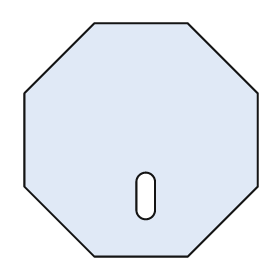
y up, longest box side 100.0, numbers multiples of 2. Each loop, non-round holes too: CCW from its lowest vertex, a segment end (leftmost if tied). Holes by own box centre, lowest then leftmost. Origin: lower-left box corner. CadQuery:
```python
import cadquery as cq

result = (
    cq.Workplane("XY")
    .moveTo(30.0, 0.0)
    .lineTo(70.0, 0.0)
    .lineTo(100.0, 30.0)
    .lineTo(100.0, 70.0)
    .lineTo(70.0, 100.0)
    .lineTo(30.0, 100.0)
    .lineTo(0.0, 70.0)
    .lineTo(0.0, 30.0)
    .close()
    .moveTo(48.0, 20.0)
    .threePointArc((52.0, 16.0), (56.0, 20.0))
    .lineTo(56.0, 32.0)
    .threePointArc((52.0, 36.0), (48.0, 32.0))
    .close()
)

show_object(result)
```